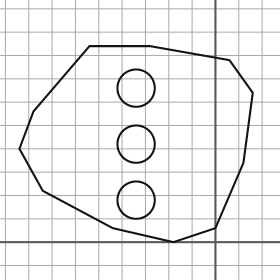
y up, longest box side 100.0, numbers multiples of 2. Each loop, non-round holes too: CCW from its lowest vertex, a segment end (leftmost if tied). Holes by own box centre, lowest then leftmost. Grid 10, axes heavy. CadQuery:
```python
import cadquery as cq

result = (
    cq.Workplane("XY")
    .moveTo(-18.0, 0.0)
    .lineTo(0.0, 6.0)
    .lineTo(12.0, 34.0)
    .lineTo(16.0, 64.0)
    .lineTo(6.0, 78.0)
    .lineTo(-28.0, 84.0)
    .lineTo(-54.0, 84.0)
    .lineTo(-78.0, 56.0)
    .lineTo(-84.0, 40.0)
    .lineTo(-74.0, 22.0)
    .lineTo(-44.0, 6.0)
    .close()
    .moveTo(-34.0, 18.0)
    .circle(8.0)
    .moveTo(-34.0, 42.0)
    .circle(8.0)
    .moveTo(-34.0, 66.0)
    .circle(8.0)
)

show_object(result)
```